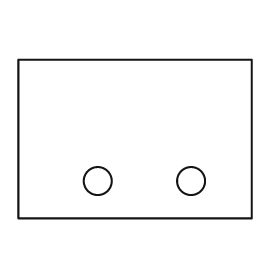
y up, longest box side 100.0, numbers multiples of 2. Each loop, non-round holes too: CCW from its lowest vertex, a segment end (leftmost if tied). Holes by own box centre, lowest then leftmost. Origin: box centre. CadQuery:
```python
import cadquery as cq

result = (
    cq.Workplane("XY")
    .moveTo(-50.0, -34.0)
    .lineTo(50.0, -34.0)
    .lineTo(50.0, 34.0)
    .lineTo(-50.0, 34.0)
    .close()
    .moveTo(-16.0, -18.0)
    .circle(6.0)
    .moveTo(24.0, -18.0)
    .circle(6.0)
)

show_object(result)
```